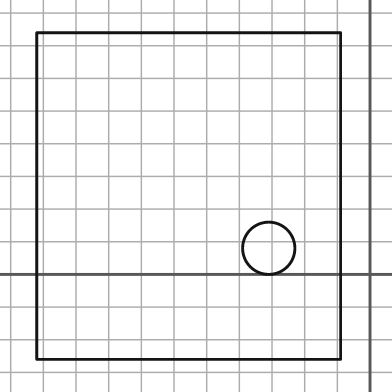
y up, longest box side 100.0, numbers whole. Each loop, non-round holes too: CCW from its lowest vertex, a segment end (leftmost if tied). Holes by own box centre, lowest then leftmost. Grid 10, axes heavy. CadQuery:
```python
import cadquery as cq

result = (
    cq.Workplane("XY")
    .moveTo(-102.0, -26.0)
    .lineTo(-9.0, -26.0)
    .lineTo(-9.0, 74.0)
    .lineTo(-102.0, 74.0)
    .close()
    .moveTo(-31.0, 8.0)
    .circle(8.0)
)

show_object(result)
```